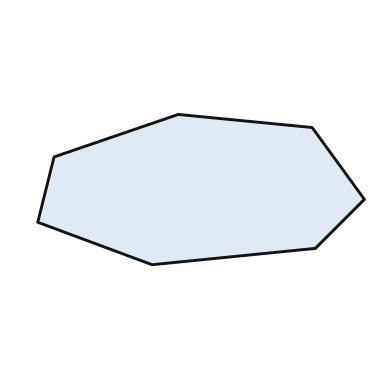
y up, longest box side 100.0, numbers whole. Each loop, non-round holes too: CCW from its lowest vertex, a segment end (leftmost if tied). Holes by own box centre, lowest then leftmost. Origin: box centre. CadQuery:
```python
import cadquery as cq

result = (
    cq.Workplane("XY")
    .moveTo(-15.0, -23.0)
    .lineTo(35.0, -18.0)
    .lineTo(50.0, -3.0)
    .lineTo(34.0, 19.0)
    .lineTo(-7.0, 23.0)
    .lineTo(-45.0, 10.0)
    .lineTo(-50.0, -10.0)
    .close()
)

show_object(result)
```